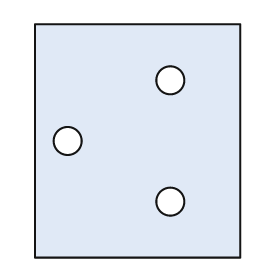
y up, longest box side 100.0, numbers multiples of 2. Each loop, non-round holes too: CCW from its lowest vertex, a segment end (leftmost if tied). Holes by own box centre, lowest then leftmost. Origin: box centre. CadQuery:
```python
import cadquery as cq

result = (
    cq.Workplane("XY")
    .moveTo(-44.0, -50.0)
    .lineTo(44.0, -50.0)
    .lineTo(44.0, 50.0)
    .lineTo(-44.0, 50.0)
    .close()
    .moveTo(14.0, -26.0)
    .circle(6.0)
    .moveTo(-30.0, 0.0)
    .circle(6.0)
    .moveTo(14.0, 26.0)
    .circle(6.0)
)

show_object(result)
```